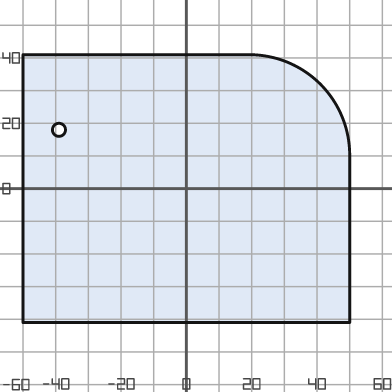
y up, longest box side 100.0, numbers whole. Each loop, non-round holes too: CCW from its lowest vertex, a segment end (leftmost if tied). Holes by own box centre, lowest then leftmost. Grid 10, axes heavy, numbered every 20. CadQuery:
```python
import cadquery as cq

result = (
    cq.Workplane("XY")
    .moveTo(-50.0, -41.0)
    .lineTo(50.0, -41.0)
    .lineTo(50.0, 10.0)
    .threePointArc((41.0, 32.0), (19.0, 41.0))
    .lineTo(-50.0, 41.0)
    .close()
    .moveTo(-39.0, 18.0)
    .circle(2.0)
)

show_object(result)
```